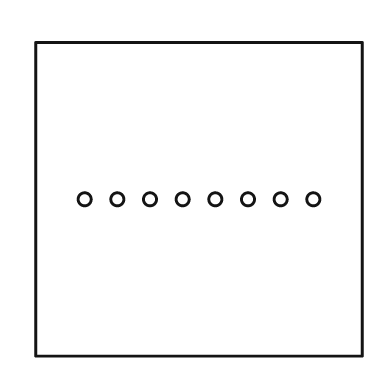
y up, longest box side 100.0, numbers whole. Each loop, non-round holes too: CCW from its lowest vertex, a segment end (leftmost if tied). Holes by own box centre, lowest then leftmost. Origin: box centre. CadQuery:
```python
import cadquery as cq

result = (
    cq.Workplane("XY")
    .moveTo(-50.0, -48.0)
    .lineTo(50.0, -48.0)
    .lineTo(50.0, 48.0)
    .lineTo(-50.0, 48.0)
    .close()
    .moveTo(-35.0, 0.0)
    .circle(2.0)
    .moveTo(-25.0, 0.0)
    .circle(2.0)
    .moveTo(-15.0, 0.0)
    .circle(2.0)
    .moveTo(-5.0, 0.0)
    .circle(2.0)
    .moveTo(5.0, 0.0)
    .circle(2.0)
    .moveTo(15.0, 0.0)
    .circle(2.0)
    .moveTo(25.0, 0.0)
    .circle(2.0)
    .moveTo(35.0, 0.0)
    .circle(2.0)
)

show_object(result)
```